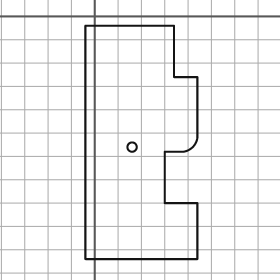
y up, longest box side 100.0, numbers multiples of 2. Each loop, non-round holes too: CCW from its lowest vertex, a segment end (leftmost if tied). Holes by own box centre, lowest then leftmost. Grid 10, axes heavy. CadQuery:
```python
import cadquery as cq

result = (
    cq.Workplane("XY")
    .moveTo(-4.0, -104.0)
    .lineTo(44.0, -104.0)
    .lineTo(44.0, -80.0)
    .lineTo(30.0, -80.0)
    .lineTo(30.0, -58.0)
    .lineTo(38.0, -58.0)
    .threePointArc((42.0, -56.0), (44.0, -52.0))
    .lineTo(44.0, -26.0)
    .lineTo(34.0, -26.0)
    .lineTo(34.0, -4.0)
    .lineTo(-4.0, -4.0)
    .close()
    .moveTo(16.0, -56.0)
    .circle(2.0)
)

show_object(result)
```